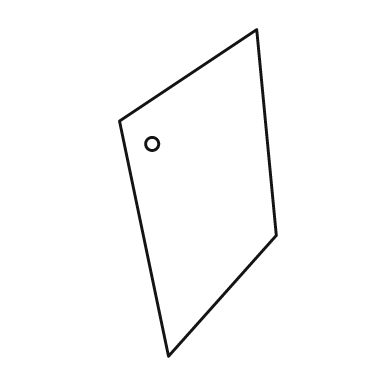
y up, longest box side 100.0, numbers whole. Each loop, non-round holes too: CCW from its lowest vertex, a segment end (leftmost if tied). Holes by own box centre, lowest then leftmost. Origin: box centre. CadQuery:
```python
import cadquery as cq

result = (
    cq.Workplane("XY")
    .moveTo(-9.0, -50.0)
    .lineTo(24.0, -13.0)
    .lineTo(18.0, 50.0)
    .lineTo(-24.0, 22.0)
    .close()
    .moveTo(-14.0, 15.0)
    .circle(2.0)
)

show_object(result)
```